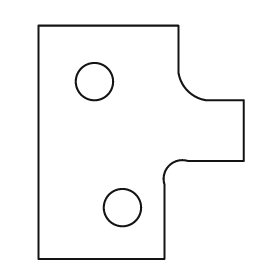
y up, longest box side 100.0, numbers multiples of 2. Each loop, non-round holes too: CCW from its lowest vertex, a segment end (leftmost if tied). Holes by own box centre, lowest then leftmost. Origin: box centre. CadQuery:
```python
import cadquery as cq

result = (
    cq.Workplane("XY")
    .moveTo(-44.0, -50.0)
    .lineTo(10.0, -50.0)
    .lineTo(10.0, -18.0)
    .threePointArc((12.0, -10.0), (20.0, -8.0))
    .lineTo(44.0, -8.0)
    .lineTo(44.0, 18.0)
    .lineTo(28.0, 18.0)
    .threePointArc((20.0, 22.0), (16.0, 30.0))
    .lineTo(16.0, 50.0)
    .lineTo(-44.0, 50.0)
    .close()
    .moveTo(-8.0, -28.0)
    .circle(8.0)
    .moveTo(-20.0, 26.0)
    .circle(8.0)
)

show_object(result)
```